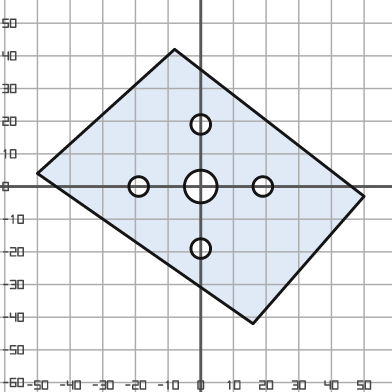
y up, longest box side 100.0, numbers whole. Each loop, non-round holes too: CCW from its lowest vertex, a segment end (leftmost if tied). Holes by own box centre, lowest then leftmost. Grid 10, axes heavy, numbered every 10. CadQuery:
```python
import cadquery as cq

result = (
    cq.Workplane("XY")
    .moveTo(16.0, -42.0)
    .lineTo(50.0, -3.0)
    .lineTo(-8.0, 42.0)
    .lineTo(-50.0, 4.0)
    .close()
    .moveTo(0.0, -19.0)
    .circle(3.0)
    .moveTo(-19.0, 0.0)
    .circle(3.0)
    .moveTo(0.0, 0.0)
    .circle(5.0)
    .moveTo(19.0, 0.0)
    .circle(3.0)
    .moveTo(0.0, 19.0)
    .circle(3.0)
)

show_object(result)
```